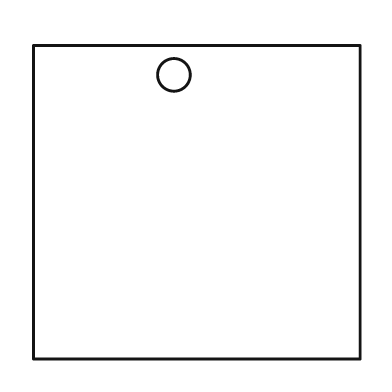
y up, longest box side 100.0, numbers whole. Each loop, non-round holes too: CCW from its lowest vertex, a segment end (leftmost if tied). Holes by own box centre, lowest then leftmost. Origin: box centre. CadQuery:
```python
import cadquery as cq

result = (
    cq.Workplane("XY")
    .moveTo(-50.0, -48.0)
    .lineTo(50.0, -48.0)
    .lineTo(50.0, 48.0)
    .lineTo(-50.0, 48.0)
    .close()
    .moveTo(-7.0, 39.0)
    .circle(5.0)
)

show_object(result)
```